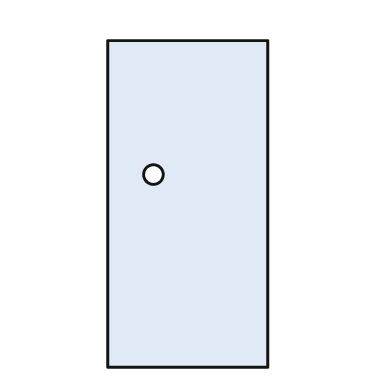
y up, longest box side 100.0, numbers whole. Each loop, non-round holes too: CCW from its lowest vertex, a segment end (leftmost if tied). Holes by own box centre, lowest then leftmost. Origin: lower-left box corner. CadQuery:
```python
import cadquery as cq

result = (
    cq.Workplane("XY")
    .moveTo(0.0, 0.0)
    .lineTo(49.0, 0.0)
    .lineTo(49.0, 100.0)
    .lineTo(0.0, 100.0)
    .close()
    .moveTo(14.0, 59.0)
    .circle(3.0)
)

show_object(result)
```